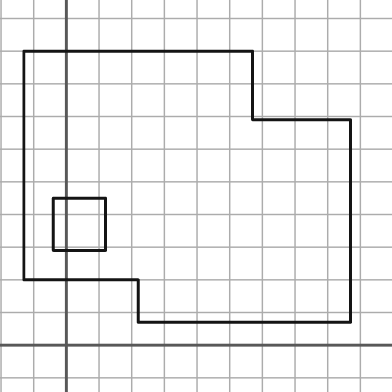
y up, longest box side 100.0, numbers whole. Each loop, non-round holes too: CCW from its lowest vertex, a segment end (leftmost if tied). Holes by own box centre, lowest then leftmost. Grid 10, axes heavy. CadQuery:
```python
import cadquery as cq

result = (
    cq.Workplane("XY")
    .moveTo(22.0, 7.0)
    .lineTo(87.0, 7.0)
    .lineTo(87.0, 69.0)
    .lineTo(57.0, 69.0)
    .lineTo(57.0, 90.0)
    .lineTo(-13.0, 90.0)
    .lineTo(-13.0, 20.0)
    .lineTo(22.0, 20.0)
    .close()
    .moveTo(-4.0, 29.0)
    .lineTo(12.0, 29.0)
    .lineTo(12.0, 45.0)
    .lineTo(-4.0, 45.0)
    .close()
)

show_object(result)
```